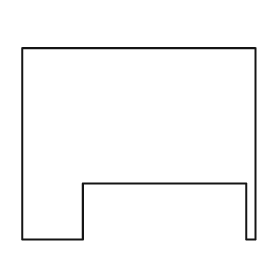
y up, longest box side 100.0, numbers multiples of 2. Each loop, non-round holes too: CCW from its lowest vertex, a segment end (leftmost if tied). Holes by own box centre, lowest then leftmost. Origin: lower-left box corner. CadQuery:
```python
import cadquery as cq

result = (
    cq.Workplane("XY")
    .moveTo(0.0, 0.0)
    .lineTo(26.0, 0.0)
    .lineTo(26.0, 24.0)
    .lineTo(96.0, 24.0)
    .lineTo(96.0, 0.0)
    .lineTo(100.0, 0.0)
    .lineTo(100.0, 82.0)
    .lineTo(0.0, 82.0)
    .close()
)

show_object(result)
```